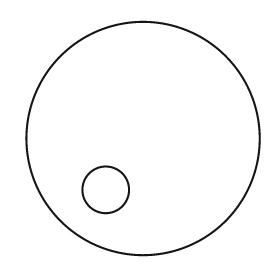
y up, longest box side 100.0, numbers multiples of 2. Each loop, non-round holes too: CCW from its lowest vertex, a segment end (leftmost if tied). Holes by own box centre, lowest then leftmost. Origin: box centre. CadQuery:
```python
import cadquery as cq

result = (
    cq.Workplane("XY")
    .moveTo(0.0, 0.0)
    .circle(50.0)
    .moveTo(-16.0, -22.0)
    .circle(10.0)
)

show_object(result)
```